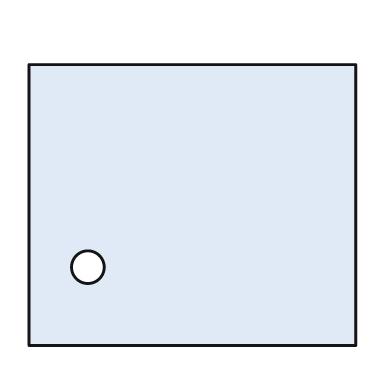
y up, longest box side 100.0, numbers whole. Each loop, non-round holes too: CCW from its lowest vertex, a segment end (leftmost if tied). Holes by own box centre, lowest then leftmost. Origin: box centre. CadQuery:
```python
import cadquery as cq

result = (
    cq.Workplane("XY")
    .moveTo(-50.0, -43.0)
    .lineTo(50.0, -43.0)
    .lineTo(50.0, 43.0)
    .lineTo(-50.0, 43.0)
    .close()
    .moveTo(-32.0, -19.0)
    .circle(5.0)
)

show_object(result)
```